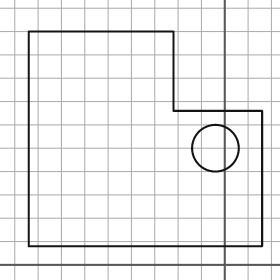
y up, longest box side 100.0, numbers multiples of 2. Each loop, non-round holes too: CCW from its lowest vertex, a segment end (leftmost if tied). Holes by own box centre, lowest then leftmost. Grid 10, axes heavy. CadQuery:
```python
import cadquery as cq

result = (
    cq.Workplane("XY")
    .moveTo(-84.0, 8.0)
    .lineTo(16.0, 8.0)
    .lineTo(16.0, 66.0)
    .lineTo(-22.0, 66.0)
    .lineTo(-22.0, 100.0)
    .lineTo(-84.0, 100.0)
    .close()
    .moveTo(-4.0, 50.0)
    .circle(10.0)
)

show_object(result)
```